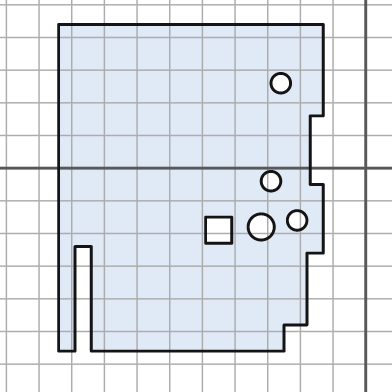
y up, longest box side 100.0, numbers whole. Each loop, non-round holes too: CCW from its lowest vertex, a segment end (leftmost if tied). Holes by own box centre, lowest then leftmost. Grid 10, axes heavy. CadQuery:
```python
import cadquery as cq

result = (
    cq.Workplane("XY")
    .moveTo(-94.0, -56.0)
    .lineTo(-89.0, -56.0)
    .lineTo(-89.0, -24.0)
    .lineTo(-84.0, -24.0)
    .lineTo(-84.0, -56.0)
    .lineTo(-25.0, -56.0)
    .lineTo(-25.0, -48.0)
    .lineTo(-18.0, -48.0)
    .lineTo(-18.0, -26.0)
    .lineTo(-13.0, -26.0)
    .lineTo(-13.0, -5.0)
    .lineTo(-17.0, -5.0)
    .lineTo(-17.0, 16.0)
    .lineTo(-13.0, 16.0)
    .lineTo(-13.0, 44.0)
    .lineTo(-94.0, 44.0)
    .close()
    .moveTo(-49.0, -23.0)
    .lineTo(-41.0, -23.0)
    .lineTo(-41.0, -15.0)
    .lineTo(-49.0, -15.0)
    .close()
    .moveTo(-32.0, -18.0)
    .circle(4.0)
    .moveTo(-21.0, -16.0)
    .circle(3.0)
    .moveTo(-29.0, -4.0)
    .circle(3.0)
    .moveTo(-26.0, 26.0)
    .circle(3.0)
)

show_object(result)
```